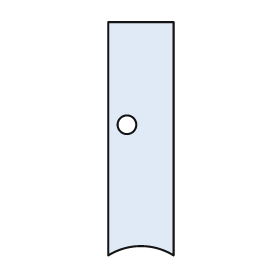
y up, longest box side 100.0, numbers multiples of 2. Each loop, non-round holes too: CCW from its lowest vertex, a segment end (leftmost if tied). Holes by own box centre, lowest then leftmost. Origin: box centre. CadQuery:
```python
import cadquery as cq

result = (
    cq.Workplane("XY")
    .moveTo(-14.0, -50.0)
    .threePointArc((0.0, -46.0), (14.0, -50.0))
    .lineTo(14.0, 50.0)
    .lineTo(-14.0, 50.0)
    .close()
    .moveTo(-6.0, 6.0)
    .circle(4.0)
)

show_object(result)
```